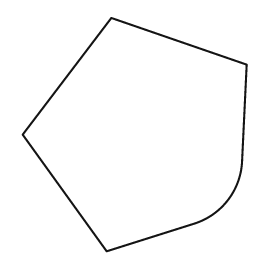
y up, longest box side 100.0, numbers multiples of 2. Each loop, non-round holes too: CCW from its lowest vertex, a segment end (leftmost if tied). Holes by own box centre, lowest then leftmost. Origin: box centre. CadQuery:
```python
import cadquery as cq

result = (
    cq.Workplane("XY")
    .moveTo(-12.0, -50.0)
    .lineTo(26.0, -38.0)
    .threePointArc((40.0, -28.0), (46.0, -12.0))
    .lineTo(48.0, 30.0)
    .lineTo(-10.0, 50.0)
    .lineTo(-48.0, 0.0)
    .close()
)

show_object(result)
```